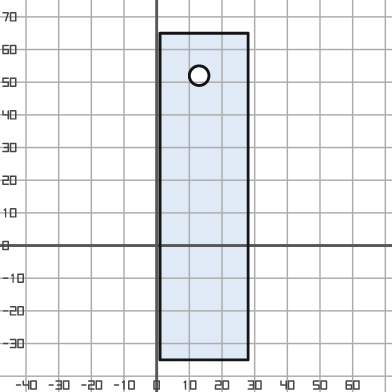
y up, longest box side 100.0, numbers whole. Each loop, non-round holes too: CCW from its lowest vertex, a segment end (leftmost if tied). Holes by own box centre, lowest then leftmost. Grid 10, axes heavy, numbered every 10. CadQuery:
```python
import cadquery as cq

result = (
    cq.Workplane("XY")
    .moveTo(1.0, -35.0)
    .lineTo(28.0, -35.0)
    .lineTo(28.0, 65.0)
    .lineTo(1.0, 65.0)
    .close()
    .moveTo(13.0, 52.0)
    .circle(3.0)
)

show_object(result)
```